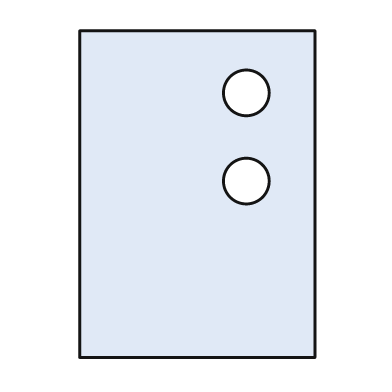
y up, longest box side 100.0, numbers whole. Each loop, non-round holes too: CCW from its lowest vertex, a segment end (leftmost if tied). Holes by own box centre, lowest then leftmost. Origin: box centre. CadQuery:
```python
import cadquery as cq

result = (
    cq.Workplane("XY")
    .moveTo(-36.0, -50.0)
    .lineTo(36.0, -50.0)
    .lineTo(36.0, 50.0)
    .lineTo(-36.0, 50.0)
    .close()
    .moveTo(15.0, 4.0)
    .circle(7.0)
    .moveTo(15.0, 31.0)
    .circle(7.0)
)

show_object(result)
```